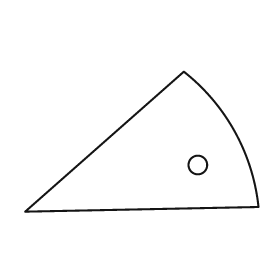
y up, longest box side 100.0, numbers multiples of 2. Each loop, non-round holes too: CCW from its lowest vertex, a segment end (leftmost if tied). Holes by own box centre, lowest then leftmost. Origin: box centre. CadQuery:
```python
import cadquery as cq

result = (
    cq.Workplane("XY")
    .moveTo(-50.0, -30.0)
    .lineTo(50.0, -28.0)
    .threePointArc((40.0, 4.0), (18.0, 30.0))
    .close()
    .moveTo(24.0, -10.0)
    .circle(4.0)
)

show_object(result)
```